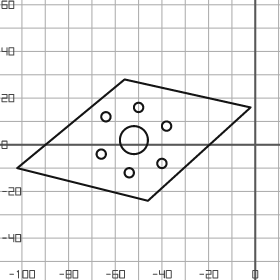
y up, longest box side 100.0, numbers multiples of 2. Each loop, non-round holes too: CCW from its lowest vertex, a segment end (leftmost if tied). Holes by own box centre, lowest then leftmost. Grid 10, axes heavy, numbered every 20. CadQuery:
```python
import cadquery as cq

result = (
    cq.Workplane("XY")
    .moveTo(-46.0, -24.0)
    .lineTo(-2.0, 16.0)
    .lineTo(-56.0, 28.0)
    .lineTo(-102.0, -10.0)
    .close()
    .moveTo(-54.0, -12.0)
    .circle(2.0)
    .moveTo(-40.0, -8.0)
    .circle(2.0)
    .moveTo(-66.0, -4.0)
    .circle(2.0)
    .moveTo(-52.0, 2.0)
    .circle(6.0)
    .moveTo(-38.0, 8.0)
    .circle(2.0)
    .moveTo(-64.0, 12.0)
    .circle(2.0)
    .moveTo(-50.0, 16.0)
    .circle(2.0)
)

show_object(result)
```